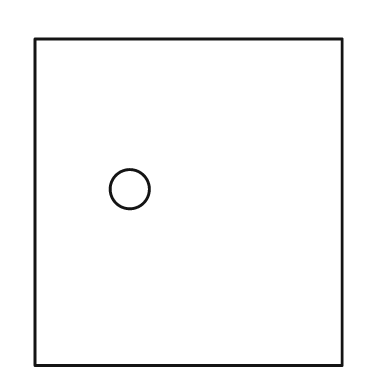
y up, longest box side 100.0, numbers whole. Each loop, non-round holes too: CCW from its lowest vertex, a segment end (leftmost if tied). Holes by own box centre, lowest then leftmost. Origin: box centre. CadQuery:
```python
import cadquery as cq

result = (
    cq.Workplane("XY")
    .moveTo(-47.0, -50.0)
    .lineTo(47.0, -50.0)
    .lineTo(47.0, 50.0)
    .lineTo(-47.0, 50.0)
    .close()
    .moveTo(-18.0, 4.0)
    .circle(6.0)
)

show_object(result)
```